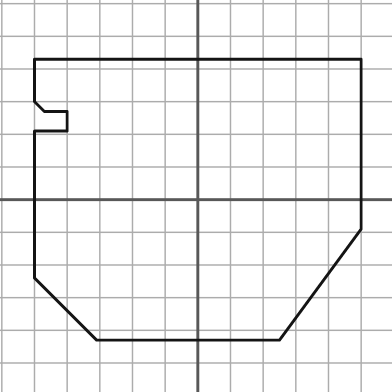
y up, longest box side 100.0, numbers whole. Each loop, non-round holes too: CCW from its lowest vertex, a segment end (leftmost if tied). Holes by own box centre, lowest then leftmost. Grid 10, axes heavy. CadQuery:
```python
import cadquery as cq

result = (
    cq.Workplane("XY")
    .moveTo(-31.0, -43.0)
    .lineTo(25.0, -43.0)
    .lineTo(50.0, -9.0)
    .lineTo(50.0, 43.0)
    .lineTo(-50.0, 43.0)
    .lineTo(-50.0, 30.0)
    .lineTo(-47.0, 27.0)
    .lineTo(-40.0, 27.0)
    .lineTo(-40.0, 21.0)
    .lineTo(-50.0, 21.0)
    .lineTo(-50.0, -24.0)
    .close()
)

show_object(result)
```